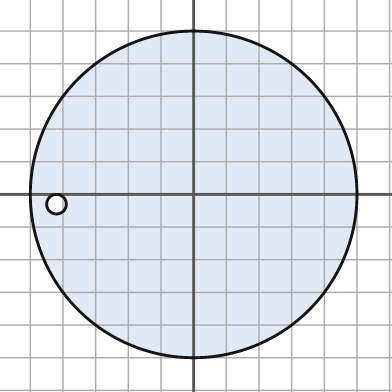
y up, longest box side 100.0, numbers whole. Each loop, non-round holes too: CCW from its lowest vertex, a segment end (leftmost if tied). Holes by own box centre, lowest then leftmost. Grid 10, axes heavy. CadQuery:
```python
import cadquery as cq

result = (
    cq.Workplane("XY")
    .moveTo(0.0, 0.0)
    .circle(50.0)
    .moveTo(-42.0, -3.0)
    .circle(3.0)
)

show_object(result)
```